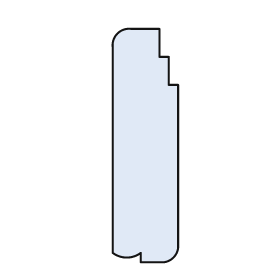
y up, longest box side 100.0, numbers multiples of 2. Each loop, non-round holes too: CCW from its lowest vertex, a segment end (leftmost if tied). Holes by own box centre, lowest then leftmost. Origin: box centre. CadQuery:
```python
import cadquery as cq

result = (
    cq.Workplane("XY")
    .moveTo(-2.0, -50.0)
    .lineTo(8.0, -50.0)
    .threePointArc((12.0, -48.0), (14.0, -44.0))
    .lineTo(14.0, 26.0)
    .lineTo(10.0, 26.0)
    .lineTo(10.0, 38.0)
    .lineTo(6.0, 38.0)
    .lineTo(6.0, 50.0)
    .lineTo(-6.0, 50.0)
    .threePointArc((-12.0, 48.0), (-14.0, 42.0))
    .lineTo(-14.0, -46.0)
    .threePointArc((-8.0, -48.0), (-2.0, -46.0))
    .close()
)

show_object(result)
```